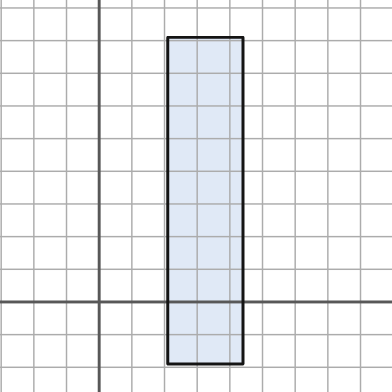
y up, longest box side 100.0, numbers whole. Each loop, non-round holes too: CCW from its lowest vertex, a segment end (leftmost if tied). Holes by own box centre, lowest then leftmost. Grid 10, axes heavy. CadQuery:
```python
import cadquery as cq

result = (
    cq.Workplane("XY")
    .moveTo(21.0, -19.0)
    .lineTo(44.0, -19.0)
    .lineTo(44.0, 81.0)
    .lineTo(21.0, 81.0)
    .close()
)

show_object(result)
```